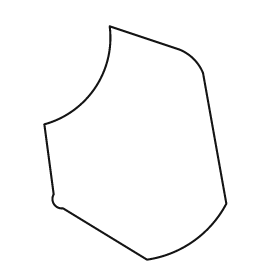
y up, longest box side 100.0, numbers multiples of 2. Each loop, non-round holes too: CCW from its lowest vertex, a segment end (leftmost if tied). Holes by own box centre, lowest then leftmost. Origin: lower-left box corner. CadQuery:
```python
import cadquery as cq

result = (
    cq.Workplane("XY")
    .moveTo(44.0, 0.0)
    .threePointArc((64.0, 8.0), (78.0, 24.0))
    .lineTo(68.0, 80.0)
    .threePointArc((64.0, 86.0), (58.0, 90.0))
    .lineTo(28.0, 100.0)
    .threePointArc((22.0, 74.0), (0.0, 58.0))
    .lineTo(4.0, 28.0)
    .threePointArc((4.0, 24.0), (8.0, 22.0))
    .close()
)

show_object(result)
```